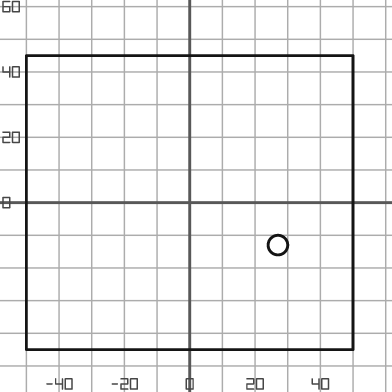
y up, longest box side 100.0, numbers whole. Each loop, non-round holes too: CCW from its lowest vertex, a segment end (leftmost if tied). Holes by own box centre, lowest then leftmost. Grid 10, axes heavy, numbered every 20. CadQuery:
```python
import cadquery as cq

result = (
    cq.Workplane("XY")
    .moveTo(-50.0, -45.0)
    .lineTo(50.0, -45.0)
    .lineTo(50.0, 45.0)
    .lineTo(-50.0, 45.0)
    .close()
    .moveTo(27.0, -13.0)
    .circle(3.0)
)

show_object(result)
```